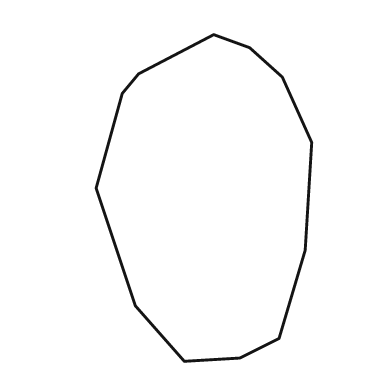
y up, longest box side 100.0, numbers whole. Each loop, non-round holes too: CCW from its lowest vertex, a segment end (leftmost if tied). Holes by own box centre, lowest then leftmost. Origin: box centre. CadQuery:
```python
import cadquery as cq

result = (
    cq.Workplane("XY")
    .moveTo(-6.0, -50.0)
    .lineTo(11.0, -49.0)
    .lineTo(23.0, -43.0)
    .lineTo(31.0, -16.0)
    .lineTo(33.0, 17.0)
    .lineTo(24.0, 37.0)
    .lineTo(14.0, 46.0)
    .lineTo(3.0, 50.0)
    .lineTo(-20.0, 38.0)
    .lineTo(-25.0, 32.0)
    .lineTo(-33.0, 3.0)
    .lineTo(-21.0, -33.0)
    .close()
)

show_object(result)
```